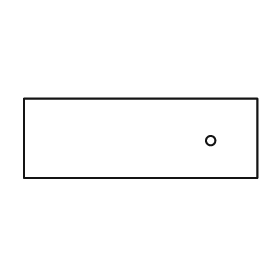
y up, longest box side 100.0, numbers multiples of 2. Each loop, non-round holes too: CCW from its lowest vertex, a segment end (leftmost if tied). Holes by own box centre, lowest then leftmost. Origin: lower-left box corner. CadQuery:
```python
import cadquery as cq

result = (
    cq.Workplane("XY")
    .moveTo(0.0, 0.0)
    .lineTo(100.0, 0.0)
    .lineTo(100.0, 34.0)
    .lineTo(0.0, 34.0)
    .close()
    .moveTo(80.0, 16.0)
    .circle(2.0)
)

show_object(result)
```